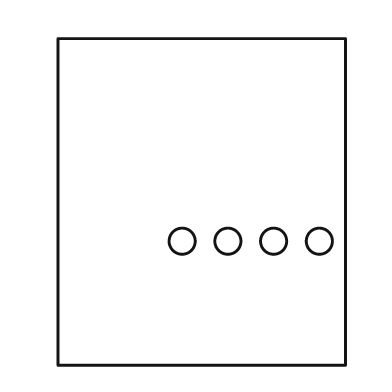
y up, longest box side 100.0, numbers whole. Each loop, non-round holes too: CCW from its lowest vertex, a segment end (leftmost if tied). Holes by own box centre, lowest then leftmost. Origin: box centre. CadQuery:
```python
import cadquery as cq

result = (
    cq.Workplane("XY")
    .moveTo(-44.0, -50.0)
    .lineTo(44.0, -50.0)
    .lineTo(44.0, 50.0)
    .lineTo(-44.0, 50.0)
    .close()
    .moveTo(-6.0, -12.0)
    .circle(4.0)
    .moveTo(8.0, -12.0)
    .circle(4.0)
    .moveTo(22.0, -12.0)
    .circle(4.0)
    .moveTo(36.0, -12.0)
    .circle(4.0)
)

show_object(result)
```